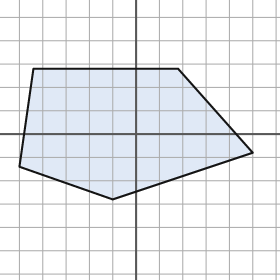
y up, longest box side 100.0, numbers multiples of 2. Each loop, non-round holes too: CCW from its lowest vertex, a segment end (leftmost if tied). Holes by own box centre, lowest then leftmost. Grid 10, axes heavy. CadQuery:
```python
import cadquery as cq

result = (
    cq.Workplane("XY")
    .moveTo(-10.0, -28.0)
    .lineTo(50.0, -8.0)
    .lineTo(18.0, 28.0)
    .lineTo(-44.0, 28.0)
    .lineTo(-50.0, -14.0)
    .close()
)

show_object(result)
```